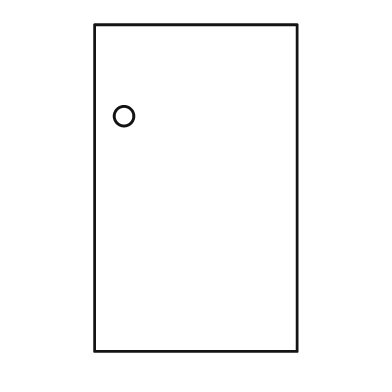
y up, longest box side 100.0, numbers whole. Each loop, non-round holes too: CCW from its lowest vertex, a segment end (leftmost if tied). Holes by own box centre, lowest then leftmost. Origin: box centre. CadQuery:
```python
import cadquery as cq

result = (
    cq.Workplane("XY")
    .moveTo(-31.0, -50.0)
    .lineTo(31.0, -50.0)
    .lineTo(31.0, 50.0)
    .lineTo(-31.0, 50.0)
    .close()
    .moveTo(-22.0, 22.0)
    .circle(3.0)
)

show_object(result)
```